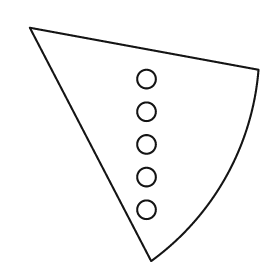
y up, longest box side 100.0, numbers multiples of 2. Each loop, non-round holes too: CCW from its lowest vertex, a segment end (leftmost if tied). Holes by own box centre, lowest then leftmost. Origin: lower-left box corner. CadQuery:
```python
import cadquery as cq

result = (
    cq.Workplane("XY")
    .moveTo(52.0, 0.0)
    .threePointArc((84.0, 36.0), (98.0, 82.0))
    .lineTo(0.0, 100.0)
    .close()
    .moveTo(50.0, 22.0)
    .circle(4.0)
    .moveTo(50.0, 36.0)
    .circle(4.0)
    .moveTo(50.0, 50.0)
    .circle(4.0)
    .moveTo(50.0, 64.0)
    .circle(4.0)
    .moveTo(50.0, 78.0)
    .circle(4.0)
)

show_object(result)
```